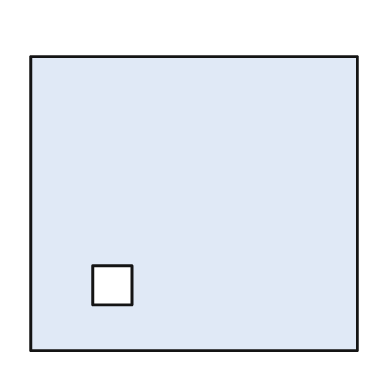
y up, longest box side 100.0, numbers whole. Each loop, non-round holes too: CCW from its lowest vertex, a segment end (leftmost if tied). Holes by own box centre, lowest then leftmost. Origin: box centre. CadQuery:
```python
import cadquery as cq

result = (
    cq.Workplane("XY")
    .moveTo(-50.0, -45.0)
    .lineTo(50.0, -45.0)
    .lineTo(50.0, 45.0)
    .lineTo(-50.0, 45.0)
    .close()
    .moveTo(-31.0, -31.0)
    .lineTo(-19.0, -31.0)
    .lineTo(-19.0, -19.0)
    .lineTo(-31.0, -19.0)
    .close()
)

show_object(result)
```